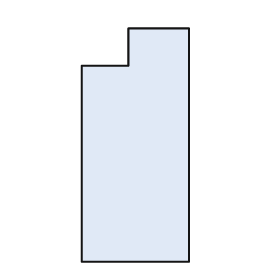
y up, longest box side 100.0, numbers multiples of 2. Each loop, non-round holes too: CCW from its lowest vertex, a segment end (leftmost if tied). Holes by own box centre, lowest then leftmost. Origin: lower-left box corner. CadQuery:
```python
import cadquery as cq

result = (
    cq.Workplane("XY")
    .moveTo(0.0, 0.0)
    .lineTo(46.0, 0.0)
    .lineTo(46.0, 100.0)
    .lineTo(20.0, 100.0)
    .lineTo(20.0, 84.0)
    .lineTo(0.0, 84.0)
    .close()
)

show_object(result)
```